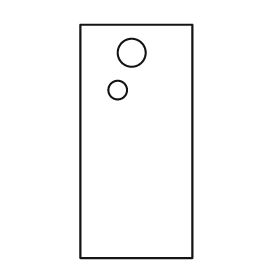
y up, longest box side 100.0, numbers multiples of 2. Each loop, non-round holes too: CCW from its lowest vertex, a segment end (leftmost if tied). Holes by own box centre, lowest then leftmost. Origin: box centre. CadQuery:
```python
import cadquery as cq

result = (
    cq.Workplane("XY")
    .moveTo(-24.0, -50.0)
    .lineTo(24.0, -50.0)
    .lineTo(24.0, 50.0)
    .lineTo(-24.0, 50.0)
    .close()
    .moveTo(-8.0, 22.0)
    .circle(4.0)
    .moveTo(-2.0, 38.0)
    .circle(6.0)
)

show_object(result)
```